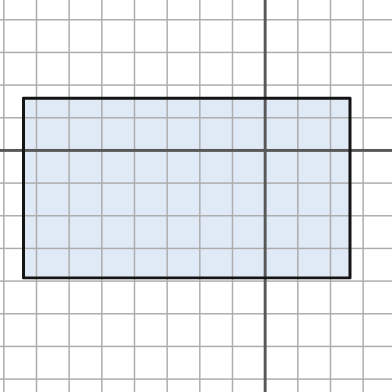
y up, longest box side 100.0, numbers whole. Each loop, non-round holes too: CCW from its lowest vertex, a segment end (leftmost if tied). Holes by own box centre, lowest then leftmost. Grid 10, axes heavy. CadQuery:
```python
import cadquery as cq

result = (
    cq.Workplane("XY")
    .moveTo(-74.0, -39.0)
    .lineTo(26.0, -39.0)
    .lineTo(26.0, 16.0)
    .lineTo(-74.0, 16.0)
    .close()
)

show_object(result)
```